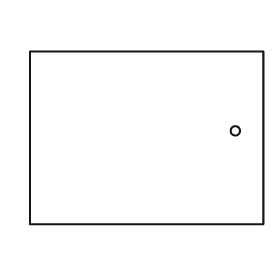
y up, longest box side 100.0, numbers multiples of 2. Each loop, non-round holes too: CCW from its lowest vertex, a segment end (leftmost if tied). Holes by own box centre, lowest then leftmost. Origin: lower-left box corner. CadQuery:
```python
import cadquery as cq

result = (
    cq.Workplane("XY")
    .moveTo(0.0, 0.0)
    .lineTo(100.0, 0.0)
    .lineTo(100.0, 74.0)
    .lineTo(0.0, 74.0)
    .close()
    .moveTo(88.0, 40.0)
    .circle(2.0)
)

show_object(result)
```